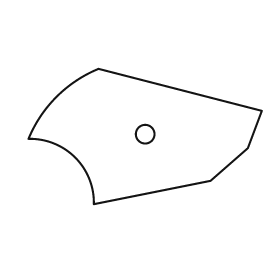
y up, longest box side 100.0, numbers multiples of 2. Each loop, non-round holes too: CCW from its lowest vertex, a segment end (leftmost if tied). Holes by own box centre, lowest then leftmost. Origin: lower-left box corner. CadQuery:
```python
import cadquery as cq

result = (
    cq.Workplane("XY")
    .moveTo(28.0, 0.0)
    .lineTo(78.0, 10.0)
    .lineTo(94.0, 24.0)
    .lineTo(100.0, 40.0)
    .lineTo(30.0, 58.0)
    .threePointArc((12.0, 46.0), (0.0, 28.0))
    .threePointArc((20.0, 20.0), (28.0, 0.0))
    .close()
    .moveTo(50.0, 30.0)
    .circle(4.0)
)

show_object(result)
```